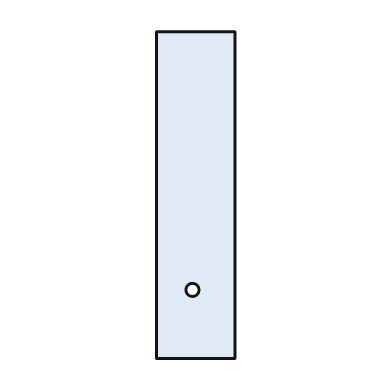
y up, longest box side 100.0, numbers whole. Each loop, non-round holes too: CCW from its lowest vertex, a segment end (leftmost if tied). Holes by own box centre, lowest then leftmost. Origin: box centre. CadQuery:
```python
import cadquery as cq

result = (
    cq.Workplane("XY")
    .moveTo(-12.0, -50.0)
    .lineTo(12.0, -50.0)
    .lineTo(12.0, 50.0)
    .lineTo(-12.0, 50.0)
    .close()
    .moveTo(-1.0, -29.0)
    .circle(2.0)
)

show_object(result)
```